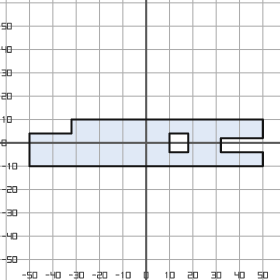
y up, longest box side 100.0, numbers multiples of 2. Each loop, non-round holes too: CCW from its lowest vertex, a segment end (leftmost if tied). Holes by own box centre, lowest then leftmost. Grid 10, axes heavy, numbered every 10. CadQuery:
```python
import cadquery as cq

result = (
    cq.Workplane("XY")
    .moveTo(-50.0, -10.0)
    .lineTo(50.0, -10.0)
    .lineTo(50.0, -4.0)
    .lineTo(32.0, -4.0)
    .lineTo(32.0, 2.0)
    .lineTo(50.0, 2.0)
    .lineTo(50.0, 10.0)
    .lineTo(-32.0, 10.0)
    .lineTo(-32.0, 4.0)
    .lineTo(-50.0, 4.0)
    .close()
    .moveTo(10.0, -4.0)
    .lineTo(18.0, -4.0)
    .lineTo(18.0, 4.0)
    .lineTo(10.0, 4.0)
    .close()
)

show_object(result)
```